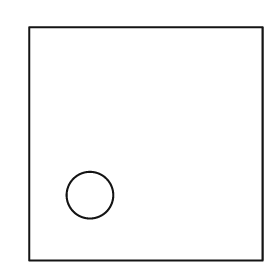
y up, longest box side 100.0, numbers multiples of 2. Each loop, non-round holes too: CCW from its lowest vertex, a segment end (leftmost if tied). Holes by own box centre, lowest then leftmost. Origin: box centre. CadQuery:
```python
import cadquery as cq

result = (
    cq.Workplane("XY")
    .moveTo(-50.0, -50.0)
    .lineTo(50.0, -50.0)
    .lineTo(50.0, 50.0)
    .lineTo(-50.0, 50.0)
    .close()
    .moveTo(-24.0, -22.0)
    .circle(10.0)
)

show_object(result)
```